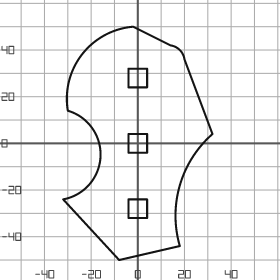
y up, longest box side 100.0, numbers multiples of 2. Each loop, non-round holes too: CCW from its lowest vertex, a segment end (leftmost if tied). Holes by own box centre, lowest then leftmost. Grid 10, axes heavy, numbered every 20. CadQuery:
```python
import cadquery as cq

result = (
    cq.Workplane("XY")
    .moveTo(-8.0, -50.0)
    .lineTo(18.0, -44.0)
    .threePointArc((18.0, -18.0), (32.0, 4.0))
    .lineTo(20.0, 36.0)
    .threePointArc((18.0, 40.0), (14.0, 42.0))
    .lineTo(-2.0, 50.0)
    .threePointArc((-24.0, 38.0), (-30.0, 14.0))
    .threePointArc((-16.0, -6.0), (-32.0, -24.0))
    .close()
    .moveTo(-4.0, -32.0)
    .lineTo(4.0, -32.0)
    .lineTo(4.0, -24.0)
    .lineTo(-4.0, -24.0)
    .close()
    .moveTo(-4.0, -4.0)
    .lineTo(4.0, -4.0)
    .lineTo(4.0, 4.0)
    .lineTo(-4.0, 4.0)
    .close()
    .moveTo(-4.0, 24.0)
    .lineTo(4.0, 24.0)
    .lineTo(4.0, 32.0)
    .lineTo(-4.0, 32.0)
    .close()
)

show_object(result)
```